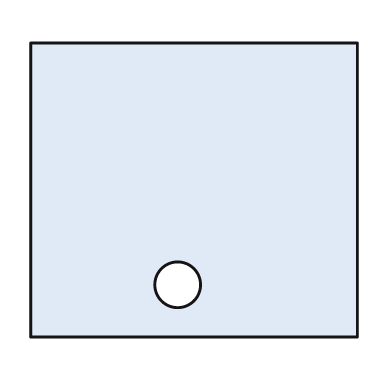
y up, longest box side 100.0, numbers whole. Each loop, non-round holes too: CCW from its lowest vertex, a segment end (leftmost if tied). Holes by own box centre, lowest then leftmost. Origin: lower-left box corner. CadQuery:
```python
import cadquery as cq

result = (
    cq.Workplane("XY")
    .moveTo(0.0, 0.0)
    .lineTo(100.0, 0.0)
    .lineTo(100.0, 90.0)
    .lineTo(0.0, 90.0)
    .close()
    .moveTo(45.0, 16.0)
    .circle(7.0)
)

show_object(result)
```